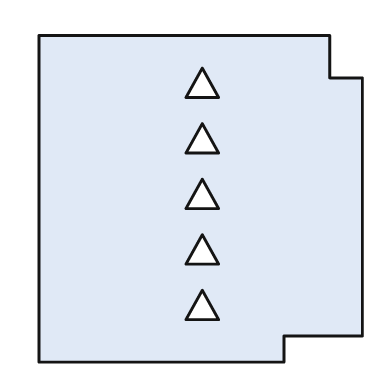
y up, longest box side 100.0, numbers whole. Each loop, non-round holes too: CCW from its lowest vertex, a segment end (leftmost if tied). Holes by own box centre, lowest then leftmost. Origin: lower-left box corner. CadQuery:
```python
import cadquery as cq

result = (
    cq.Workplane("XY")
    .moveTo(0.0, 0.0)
    .lineTo(75.0, 0.0)
    .lineTo(75.0, 8.0)
    .lineTo(99.0, 8.0)
    .lineTo(99.0, 87.0)
    .lineTo(89.0, 87.0)
    .lineTo(89.0, 100.0)
    .lineTo(0.0, 100.0)
    .close()
    .moveTo(45.0, 13.0)
    .lineTo(55.0, 13.0)
    .lineTo(50.0, 22.0)
    .close()
    .moveTo(45.0, 30.0)
    .lineTo(55.0, 30.0)
    .lineTo(50.0, 39.0)
    .close()
    .moveTo(45.0, 47.0)
    .lineTo(55.0, 47.0)
    .lineTo(50.0, 56.0)
    .close()
    .moveTo(45.0, 64.0)
    .lineTo(55.0, 64.0)
    .lineTo(50.0, 73.0)
    .close()
    .moveTo(45.0, 81.0)
    .lineTo(55.0, 81.0)
    .lineTo(50.0, 90.0)
    .close()
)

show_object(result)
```